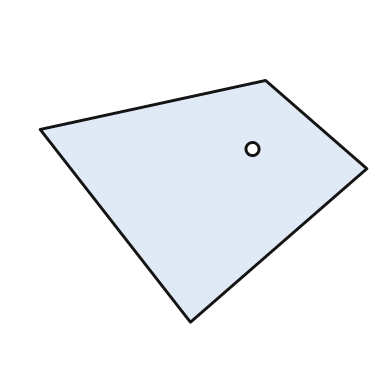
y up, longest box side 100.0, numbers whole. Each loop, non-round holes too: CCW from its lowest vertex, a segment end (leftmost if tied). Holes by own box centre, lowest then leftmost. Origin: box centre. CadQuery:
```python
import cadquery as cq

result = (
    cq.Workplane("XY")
    .moveTo(-4.0, -37.0)
    .lineTo(50.0, 10.0)
    .lineTo(19.0, 37.0)
    .lineTo(-50.0, 22.0)
    .close()
    .moveTo(15.0, 16.0)
    .circle(2.0)
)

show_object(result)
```